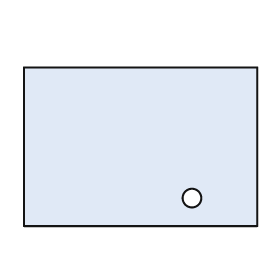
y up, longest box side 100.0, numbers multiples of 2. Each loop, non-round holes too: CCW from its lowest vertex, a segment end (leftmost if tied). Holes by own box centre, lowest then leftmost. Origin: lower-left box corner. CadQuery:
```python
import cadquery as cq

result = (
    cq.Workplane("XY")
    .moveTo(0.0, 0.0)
    .lineTo(100.0, 0.0)
    .lineTo(100.0, 68.0)
    .lineTo(0.0, 68.0)
    .close()
    .moveTo(72.0, 12.0)
    .circle(4.0)
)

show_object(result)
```